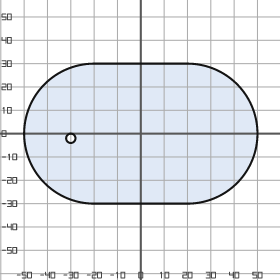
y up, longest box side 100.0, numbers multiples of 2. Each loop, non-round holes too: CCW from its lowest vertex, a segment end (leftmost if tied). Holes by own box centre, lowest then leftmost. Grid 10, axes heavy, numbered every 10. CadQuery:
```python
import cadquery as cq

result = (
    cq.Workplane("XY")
    .moveTo(-20.0, -30.0)
    .lineTo(20.0, -30.0)
    .threePointArc((50.0, 0.0), (20.0, 30.0))
    .lineTo(-20.0, 30.0)
    .threePointArc((-50.0, 0.0), (-20.0, -30.0))
    .close()
    .moveTo(-30.0, -2.0)
    .circle(2.0)
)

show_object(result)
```